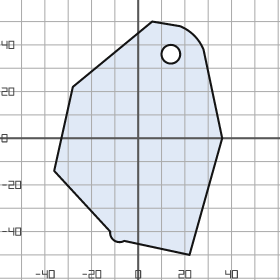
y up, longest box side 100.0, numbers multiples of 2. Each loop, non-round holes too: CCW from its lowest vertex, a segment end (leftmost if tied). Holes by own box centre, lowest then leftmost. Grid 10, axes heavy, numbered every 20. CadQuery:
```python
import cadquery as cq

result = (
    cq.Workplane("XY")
    .moveTo(22.0, -50.0)
    .lineTo(36.0, 0.0)
    .lineTo(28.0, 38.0)
    .threePointArc((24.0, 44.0), (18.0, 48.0))
    .lineTo(6.0, 50.0)
    .lineTo(-28.0, 22.0)
    .lineTo(-36.0, -14.0)
    .lineTo(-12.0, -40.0)
    .threePointArc((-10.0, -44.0), (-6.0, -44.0))
    .close()
    .moveTo(14.0, 36.0)
    .circle(4.0)
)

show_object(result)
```